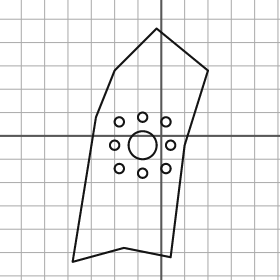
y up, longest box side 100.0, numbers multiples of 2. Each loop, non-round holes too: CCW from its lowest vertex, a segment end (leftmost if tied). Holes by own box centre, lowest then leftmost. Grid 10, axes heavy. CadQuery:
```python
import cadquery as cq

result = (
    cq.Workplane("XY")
    .moveTo(-38.0, -54.0)
    .lineTo(-16.0, -48.0)
    .lineTo(4.0, -52.0)
    .lineTo(10.0, -4.0)
    .lineTo(20.0, 28.0)
    .lineTo(-2.0, 46.0)
    .lineTo(-20.0, 28.0)
    .lineTo(-28.0, 8.0)
    .close()
    .moveTo(-8.0, -16.0)
    .circle(2.0)
    .moveTo(-18.0, -14.0)
    .circle(2.0)
    .moveTo(2.0, -14.0)
    .circle(2.0)
    .moveTo(-20.0, -4.0)
    .circle(2.0)
    .moveTo(-8.0, -4.0)
    .circle(6.0)
    .moveTo(4.0, -4.0)
    .circle(2.0)
    .moveTo(-18.0, 6.0)
    .circle(2.0)
    .moveTo(2.0, 6.0)
    .circle(2.0)
    .moveTo(-8.0, 8.0)
    .circle(2.0)
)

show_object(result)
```